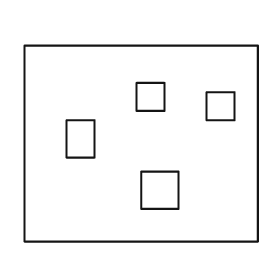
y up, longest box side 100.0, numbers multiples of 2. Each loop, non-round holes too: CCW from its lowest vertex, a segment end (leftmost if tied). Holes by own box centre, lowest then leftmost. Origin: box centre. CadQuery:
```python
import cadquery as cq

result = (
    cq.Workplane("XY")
    .moveTo(-50.0, -42.0)
    .lineTo(50.0, -42.0)
    .lineTo(50.0, 42.0)
    .lineTo(-50.0, 42.0)
    .close()
    .moveTo(0.0, -28.0)
    .lineTo(16.0, -28.0)
    .lineTo(16.0, -12.0)
    .lineTo(0.0, -12.0)
    .close()
    .moveTo(-32.0, -6.0)
    .lineTo(-20.0, -6.0)
    .lineTo(-20.0, 10.0)
    .lineTo(-32.0, 10.0)
    .close()
    .moveTo(28.0, 10.0)
    .lineTo(40.0, 10.0)
    .lineTo(40.0, 22.0)
    .lineTo(28.0, 22.0)
    .close()
    .moveTo(-2.0, 14.0)
    .lineTo(10.0, 14.0)
    .lineTo(10.0, 26.0)
    .lineTo(-2.0, 26.0)
    .close()
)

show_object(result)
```